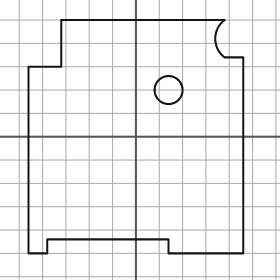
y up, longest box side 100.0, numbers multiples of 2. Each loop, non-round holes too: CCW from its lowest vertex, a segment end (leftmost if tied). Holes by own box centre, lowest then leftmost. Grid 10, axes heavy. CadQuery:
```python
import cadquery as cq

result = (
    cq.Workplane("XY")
    .moveTo(-46.0, -50.0)
    .lineTo(-38.0, -50.0)
    .lineTo(-38.0, -44.0)
    .lineTo(14.0, -44.0)
    .lineTo(14.0, -50.0)
    .lineTo(46.0, -50.0)
    .lineTo(46.0, 34.0)
    .lineTo(38.0, 34.0)
    .threePointArc((34.0, 42.0), (38.0, 50.0))
    .lineTo(-32.0, 50.0)
    .lineTo(-32.0, 30.0)
    .lineTo(-46.0, 30.0)
    .close()
    .moveTo(14.0, 20.0)
    .circle(6.0)
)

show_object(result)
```